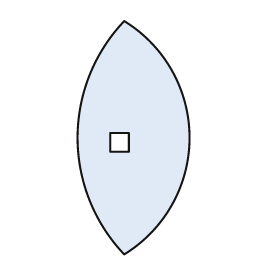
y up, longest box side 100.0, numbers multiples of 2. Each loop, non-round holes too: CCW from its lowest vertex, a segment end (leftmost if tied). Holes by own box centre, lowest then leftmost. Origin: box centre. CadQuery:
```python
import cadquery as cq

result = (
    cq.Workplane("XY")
    .moveTo(-4.0, -50.0)
    .threePointArc((24.0, 0.0), (-4.0, 50.0))
    .threePointArc((-24.0, 0.0), (-4.0, -50.0))
    .close()
    .moveTo(-10.0, -6.0)
    .lineTo(-2.0, -6.0)
    .lineTo(-2.0, 2.0)
    .lineTo(-10.0, 2.0)
    .close()
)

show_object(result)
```